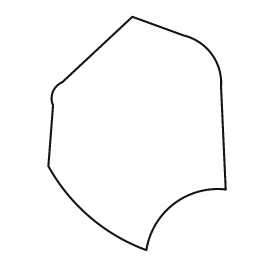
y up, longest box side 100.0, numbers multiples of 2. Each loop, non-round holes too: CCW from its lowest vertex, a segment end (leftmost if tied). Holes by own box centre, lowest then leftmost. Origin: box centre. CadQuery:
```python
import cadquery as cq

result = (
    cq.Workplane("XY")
    .moveTo(4.0, -50.0)
    .threePointArc((16.0, -30.0), (38.0, -24.0))
    .lineTo(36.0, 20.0)
    .threePointArc((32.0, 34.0), (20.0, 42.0))
    .lineTo(-2.0, 50.0)
    .lineTo(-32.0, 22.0)
    .threePointArc((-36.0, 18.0), (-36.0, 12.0))
    .lineTo(-38.0, -14.0)
    .threePointArc((-20.0, -36.0), (4.0, -50.0))
    .close()
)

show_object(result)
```